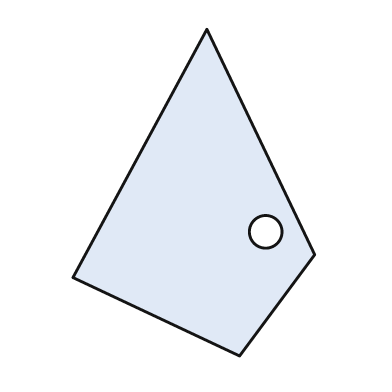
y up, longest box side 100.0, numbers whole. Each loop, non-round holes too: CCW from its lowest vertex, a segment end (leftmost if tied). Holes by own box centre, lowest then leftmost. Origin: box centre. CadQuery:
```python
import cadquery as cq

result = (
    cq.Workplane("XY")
    .moveTo(14.0, -50.0)
    .lineTo(37.0, -19.0)
    .lineTo(4.0, 50.0)
    .lineTo(-37.0, -26.0)
    .close()
    .moveTo(22.0, -12.0)
    .circle(5.0)
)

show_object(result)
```